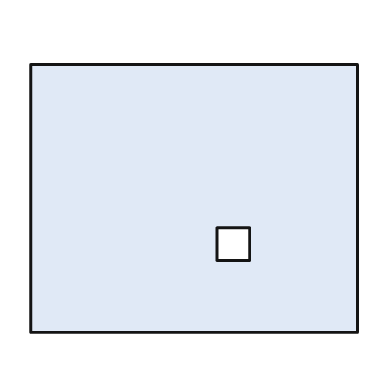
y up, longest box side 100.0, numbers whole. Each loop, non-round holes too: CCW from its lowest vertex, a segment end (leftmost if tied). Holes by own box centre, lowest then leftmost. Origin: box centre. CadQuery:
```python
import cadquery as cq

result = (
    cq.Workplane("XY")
    .moveTo(-50.0, -41.0)
    .lineTo(50.0, -41.0)
    .lineTo(50.0, 41.0)
    .lineTo(-50.0, 41.0)
    .close()
    .moveTo(7.0, -19.0)
    .lineTo(17.0, -19.0)
    .lineTo(17.0, -9.0)
    .lineTo(7.0, -9.0)
    .close()
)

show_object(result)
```